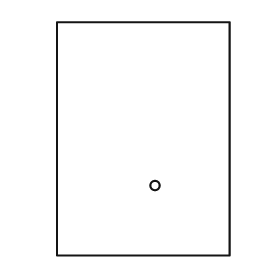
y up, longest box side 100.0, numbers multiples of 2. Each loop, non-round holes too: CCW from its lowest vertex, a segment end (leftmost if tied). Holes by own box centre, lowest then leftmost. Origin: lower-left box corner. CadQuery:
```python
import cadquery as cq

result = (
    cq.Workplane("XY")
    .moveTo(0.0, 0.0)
    .lineTo(74.0, 0.0)
    .lineTo(74.0, 100.0)
    .lineTo(0.0, 100.0)
    .close()
    .moveTo(42.0, 30.0)
    .circle(2.0)
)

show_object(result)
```